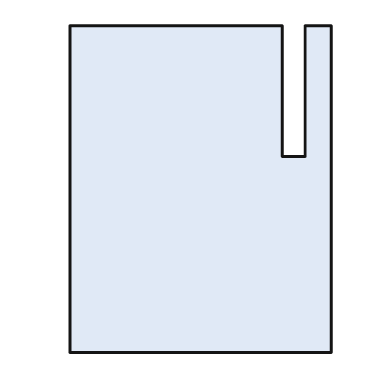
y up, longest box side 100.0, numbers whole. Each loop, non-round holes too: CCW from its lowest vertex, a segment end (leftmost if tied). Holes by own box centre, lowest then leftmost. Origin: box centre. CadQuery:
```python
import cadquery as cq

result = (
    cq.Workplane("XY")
    .moveTo(-40.0, -50.0)
    .lineTo(40.0, -50.0)
    .lineTo(40.0, 50.0)
    .lineTo(32.0, 50.0)
    .lineTo(32.0, 10.0)
    .lineTo(25.0, 10.0)
    .lineTo(25.0, 50.0)
    .lineTo(-40.0, 50.0)
    .close()
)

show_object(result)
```